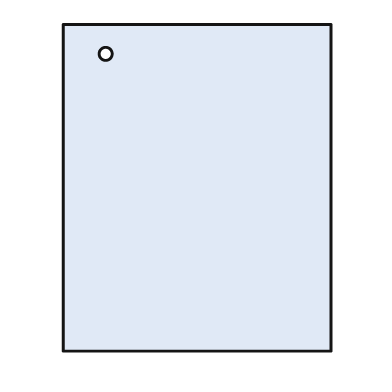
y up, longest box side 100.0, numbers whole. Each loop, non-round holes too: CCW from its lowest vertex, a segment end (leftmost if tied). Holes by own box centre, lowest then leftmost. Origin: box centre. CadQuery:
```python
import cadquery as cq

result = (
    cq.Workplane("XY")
    .moveTo(-41.0, -50.0)
    .lineTo(41.0, -50.0)
    .lineTo(41.0, 50.0)
    .lineTo(-41.0, 50.0)
    .close()
    .moveTo(-28.0, 41.0)
    .circle(2.0)
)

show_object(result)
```